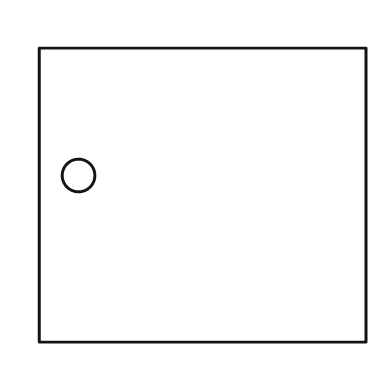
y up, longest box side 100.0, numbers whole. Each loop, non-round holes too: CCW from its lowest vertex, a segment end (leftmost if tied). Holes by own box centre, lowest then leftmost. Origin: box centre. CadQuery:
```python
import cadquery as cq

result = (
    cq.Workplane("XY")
    .moveTo(-50.0, -45.0)
    .lineTo(50.0, -45.0)
    .lineTo(50.0, 45.0)
    .lineTo(-50.0, 45.0)
    .close()
    .moveTo(-38.0, 6.0)
    .circle(5.0)
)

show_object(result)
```